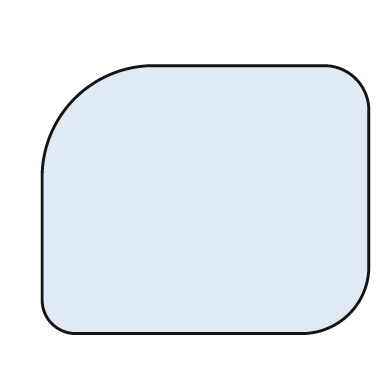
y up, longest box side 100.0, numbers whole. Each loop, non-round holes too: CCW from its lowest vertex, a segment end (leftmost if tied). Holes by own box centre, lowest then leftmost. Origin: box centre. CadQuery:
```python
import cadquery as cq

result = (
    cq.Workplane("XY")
    .moveTo(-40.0, -41.0)
    .lineTo(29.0, -41.0)
    .threePointArc((44.0, -35.0), (50.0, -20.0))
    .lineTo(50.0, 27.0)
    .threePointArc((46.0, 37.0), (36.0, 41.0))
    .lineTo(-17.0, 41.0)
    .threePointArc((-40.0, 31.0), (-50.0, 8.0))
    .lineTo(-50.0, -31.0)
    .threePointArc((-47.0, -38.0), (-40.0, -41.0))
    .close()
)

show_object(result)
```